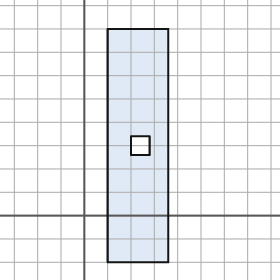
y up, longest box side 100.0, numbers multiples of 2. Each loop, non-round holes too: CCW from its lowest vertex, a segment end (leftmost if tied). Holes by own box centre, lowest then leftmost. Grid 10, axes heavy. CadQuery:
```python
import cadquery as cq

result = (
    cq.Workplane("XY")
    .moveTo(10.0, -20.0)
    .lineTo(36.0, -20.0)
    .lineTo(36.0, 80.0)
    .lineTo(10.0, 80.0)
    .close()
    .moveTo(20.0, 26.0)
    .lineTo(28.0, 26.0)
    .lineTo(28.0, 34.0)
    .lineTo(20.0, 34.0)
    .close()
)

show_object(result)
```